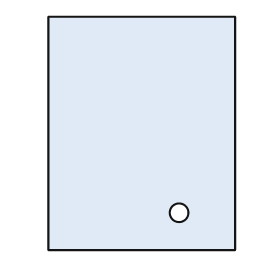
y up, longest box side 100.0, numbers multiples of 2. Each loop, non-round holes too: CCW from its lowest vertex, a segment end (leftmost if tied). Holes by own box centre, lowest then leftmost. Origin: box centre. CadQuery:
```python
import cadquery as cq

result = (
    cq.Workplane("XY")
    .moveTo(-40.0, -50.0)
    .lineTo(40.0, -50.0)
    .lineTo(40.0, 50.0)
    .lineTo(-40.0, 50.0)
    .close()
    .moveTo(16.0, -34.0)
    .circle(4.0)
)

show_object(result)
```